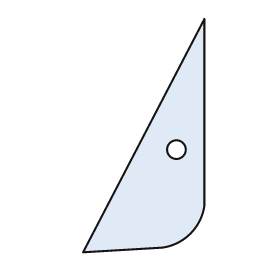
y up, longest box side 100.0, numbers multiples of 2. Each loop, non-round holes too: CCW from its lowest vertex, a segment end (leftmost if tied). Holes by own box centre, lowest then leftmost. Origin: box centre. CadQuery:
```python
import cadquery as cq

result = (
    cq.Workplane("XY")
    .moveTo(-26.0, -50.0)
    .lineTo(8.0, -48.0)
    .threePointArc((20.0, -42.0), (26.0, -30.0))
    .lineTo(26.0, 50.0)
    .close()
    .moveTo(14.0, -6.0)
    .circle(4.0)
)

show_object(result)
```